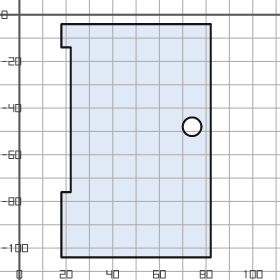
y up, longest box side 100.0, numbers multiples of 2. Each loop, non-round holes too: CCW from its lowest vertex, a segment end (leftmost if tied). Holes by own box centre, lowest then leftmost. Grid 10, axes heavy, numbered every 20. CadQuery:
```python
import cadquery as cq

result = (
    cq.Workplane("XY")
    .moveTo(18.0, -104.0)
    .lineTo(82.0, -104.0)
    .lineTo(82.0, -4.0)
    .lineTo(18.0, -4.0)
    .lineTo(18.0, -14.0)
    .lineTo(22.0, -14.0)
    .lineTo(22.0, -76.0)
    .lineTo(18.0, -76.0)
    .close()
    .moveTo(74.0, -48.0)
    .circle(4.0)
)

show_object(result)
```